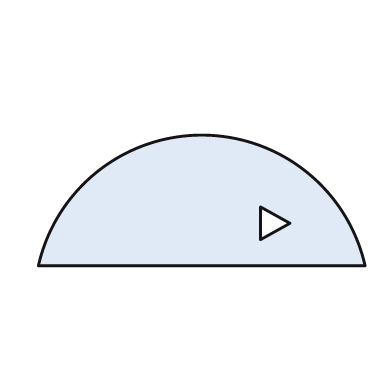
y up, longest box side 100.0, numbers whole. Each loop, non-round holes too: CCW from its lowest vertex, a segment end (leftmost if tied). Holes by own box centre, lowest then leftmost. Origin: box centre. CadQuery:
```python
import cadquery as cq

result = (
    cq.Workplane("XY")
    .moveTo(-50.0, -20.0)
    .lineTo(50.0, -20.0)
    .threePointArc((0.0, 20.0), (-50.0, -20.0))
    .close()
    .moveTo(18.0, -12.0)
    .lineTo(27.0, -7.0)
    .lineTo(18.0, -2.0)
    .close()
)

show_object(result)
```